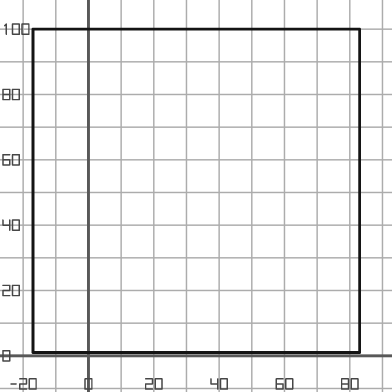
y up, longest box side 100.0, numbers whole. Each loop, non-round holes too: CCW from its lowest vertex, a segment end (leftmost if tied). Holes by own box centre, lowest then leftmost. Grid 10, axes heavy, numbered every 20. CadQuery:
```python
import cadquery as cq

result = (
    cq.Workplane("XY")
    .moveTo(-17.0, 1.0)
    .lineTo(83.0, 1.0)
    .lineTo(83.0, 100.0)
    .lineTo(-17.0, 100.0)
    .close()
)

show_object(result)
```